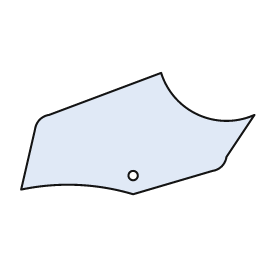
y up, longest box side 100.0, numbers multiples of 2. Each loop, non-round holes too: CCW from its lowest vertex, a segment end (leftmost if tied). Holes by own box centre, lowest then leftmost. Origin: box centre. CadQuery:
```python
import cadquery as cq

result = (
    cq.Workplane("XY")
    .moveTo(-2.0, -26.0)
    .lineTo(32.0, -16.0)
    .threePointArc((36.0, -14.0), (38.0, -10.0))
    .lineTo(50.0, 8.0)
    .threePointArc((26.0, 8.0), (10.0, 26.0))
    .lineTo(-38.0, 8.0)
    .threePointArc((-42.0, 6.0), (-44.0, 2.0))
    .lineTo(-50.0, -24.0)
    .threePointArc((-26.0, -22.0), (-2.0, -26.0))
    .close()
    .moveTo(-2.0, -18.0)
    .circle(2.0)
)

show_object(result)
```